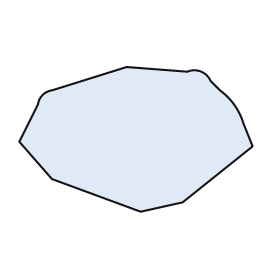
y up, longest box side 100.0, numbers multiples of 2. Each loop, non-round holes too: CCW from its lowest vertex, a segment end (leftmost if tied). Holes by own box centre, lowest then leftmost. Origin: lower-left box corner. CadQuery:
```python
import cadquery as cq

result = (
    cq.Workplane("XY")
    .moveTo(52.0, 0.0)
    .lineTo(70.0, 4.0)
    .lineTo(100.0, 28.0)
    .lineTo(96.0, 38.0)
    .threePointArc((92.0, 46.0), (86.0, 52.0))
    .lineTo(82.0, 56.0)
    .threePointArc((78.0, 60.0), (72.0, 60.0))
    .lineTo(46.0, 62.0)
    .lineTo(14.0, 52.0)
    .threePointArc((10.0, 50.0), (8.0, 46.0))
    .lineTo(0.0, 30.0)
    .lineTo(14.0, 14.0)
    .close()
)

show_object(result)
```